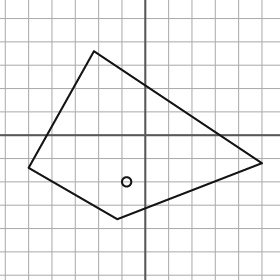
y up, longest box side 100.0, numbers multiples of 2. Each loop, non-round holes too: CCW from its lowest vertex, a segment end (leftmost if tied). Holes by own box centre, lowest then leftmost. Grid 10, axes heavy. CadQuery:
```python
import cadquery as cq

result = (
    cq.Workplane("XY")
    .moveTo(-12.0, -36.0)
    .lineTo(50.0, -12.0)
    .lineTo(-22.0, 36.0)
    .lineTo(-50.0, -14.0)
    .close()
    .moveTo(-8.0, -20.0)
    .circle(2.0)
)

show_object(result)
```